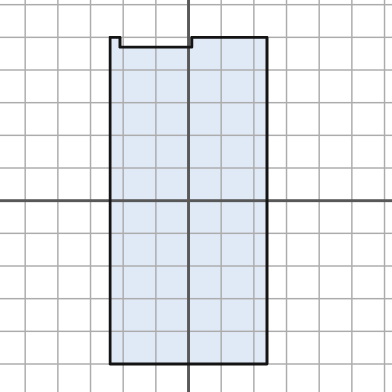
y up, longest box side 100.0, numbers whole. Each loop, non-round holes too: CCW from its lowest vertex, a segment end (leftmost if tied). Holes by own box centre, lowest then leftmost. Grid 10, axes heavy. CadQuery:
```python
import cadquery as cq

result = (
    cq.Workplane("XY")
    .moveTo(-24.0, -50.0)
    .lineTo(24.0, -50.0)
    .lineTo(24.0, 50.0)
    .lineTo(1.0, 50.0)
    .lineTo(1.0, 47.0)
    .lineTo(-21.0, 47.0)
    .lineTo(-21.0, 50.0)
    .lineTo(-24.0, 50.0)
    .close()
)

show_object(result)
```